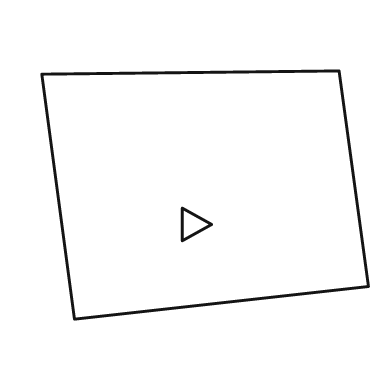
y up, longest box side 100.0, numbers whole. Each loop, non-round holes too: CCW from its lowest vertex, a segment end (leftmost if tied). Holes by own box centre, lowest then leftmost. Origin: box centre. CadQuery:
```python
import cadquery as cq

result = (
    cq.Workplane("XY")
    .moveTo(-40.0, -38.0)
    .lineTo(50.0, -28.0)
    .lineTo(41.0, 38.0)
    .lineTo(-50.0, 37.0)
    .close()
    .moveTo(-7.0, -14.0)
    .lineTo(2.0, -9.0)
    .lineTo(-7.0, -4.0)
    .close()
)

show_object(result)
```